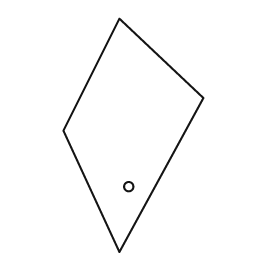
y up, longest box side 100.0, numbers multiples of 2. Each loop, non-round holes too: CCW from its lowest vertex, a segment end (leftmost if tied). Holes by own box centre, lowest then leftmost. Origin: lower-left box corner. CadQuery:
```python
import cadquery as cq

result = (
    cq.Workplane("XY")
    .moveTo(24.0, 0.0)
    .lineTo(60.0, 66.0)
    .lineTo(24.0, 100.0)
    .lineTo(0.0, 52.0)
    .close()
    .moveTo(28.0, 28.0)
    .circle(2.0)
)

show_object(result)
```